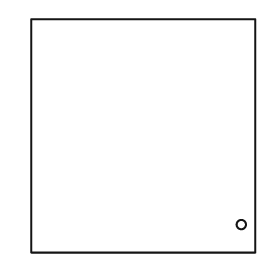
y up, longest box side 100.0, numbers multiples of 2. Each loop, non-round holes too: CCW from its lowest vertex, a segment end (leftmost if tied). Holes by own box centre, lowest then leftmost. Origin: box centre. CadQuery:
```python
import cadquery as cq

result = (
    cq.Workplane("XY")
    .moveTo(-48.0, -50.0)
    .lineTo(48.0, -50.0)
    .lineTo(48.0, 50.0)
    .lineTo(-48.0, 50.0)
    .close()
    .moveTo(42.0, -38.0)
    .circle(2.0)
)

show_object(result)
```